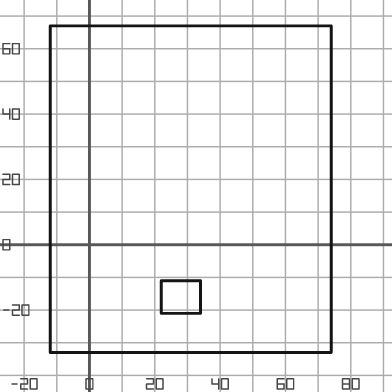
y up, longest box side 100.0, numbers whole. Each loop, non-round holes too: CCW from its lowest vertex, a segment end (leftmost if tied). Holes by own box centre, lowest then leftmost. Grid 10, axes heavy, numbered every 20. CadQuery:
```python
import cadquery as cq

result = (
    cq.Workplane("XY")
    .moveTo(-12.0, -33.0)
    .lineTo(74.0, -33.0)
    .lineTo(74.0, 67.0)
    .lineTo(-12.0, 67.0)
    .close()
    .moveTo(22.0, -21.0)
    .lineTo(34.0, -21.0)
    .lineTo(34.0, -11.0)
    .lineTo(22.0, -11.0)
    .close()
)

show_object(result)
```